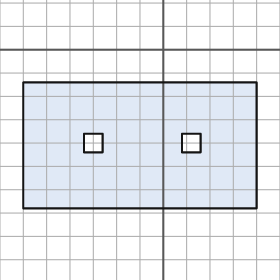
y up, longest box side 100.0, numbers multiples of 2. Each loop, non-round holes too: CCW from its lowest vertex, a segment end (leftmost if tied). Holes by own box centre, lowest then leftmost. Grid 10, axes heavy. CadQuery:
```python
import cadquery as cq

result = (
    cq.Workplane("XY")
    .moveTo(-60.0, -68.0)
    .lineTo(40.0, -68.0)
    .lineTo(40.0, -14.0)
    .lineTo(-60.0, -14.0)
    .close()
    .moveTo(-34.0, -44.0)
    .lineTo(-26.0, -44.0)
    .lineTo(-26.0, -36.0)
    .lineTo(-34.0, -36.0)
    .close()
    .moveTo(8.0, -44.0)
    .lineTo(16.0, -44.0)
    .lineTo(16.0, -36.0)
    .lineTo(8.0, -36.0)
    .close()
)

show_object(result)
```